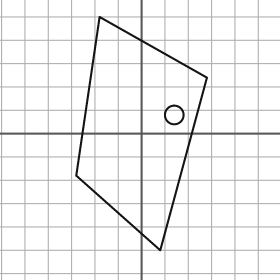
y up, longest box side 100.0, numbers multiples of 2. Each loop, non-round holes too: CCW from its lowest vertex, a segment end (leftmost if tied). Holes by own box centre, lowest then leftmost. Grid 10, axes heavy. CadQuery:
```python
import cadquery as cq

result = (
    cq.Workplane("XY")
    .moveTo(8.0, -50.0)
    .lineTo(28.0, 24.0)
    .lineTo(-18.0, 50.0)
    .lineTo(-28.0, -18.0)
    .close()
    .moveTo(14.0, 8.0)
    .circle(4.0)
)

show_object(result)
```